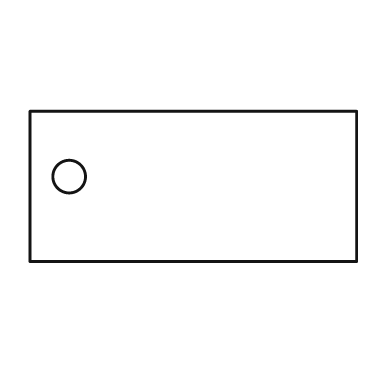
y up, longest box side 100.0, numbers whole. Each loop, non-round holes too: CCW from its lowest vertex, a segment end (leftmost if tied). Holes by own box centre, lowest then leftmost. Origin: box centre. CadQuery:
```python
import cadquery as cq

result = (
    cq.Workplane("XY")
    .moveTo(-50.0, -23.0)
    .lineTo(50.0, -23.0)
    .lineTo(50.0, 23.0)
    .lineTo(-50.0, 23.0)
    .close()
    .moveTo(-38.0, 3.0)
    .circle(5.0)
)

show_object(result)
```